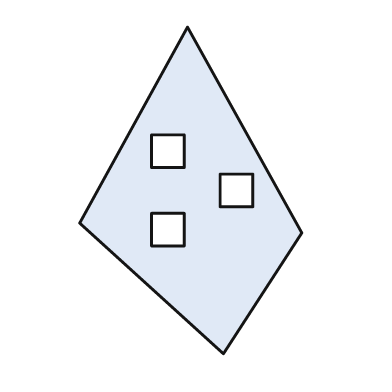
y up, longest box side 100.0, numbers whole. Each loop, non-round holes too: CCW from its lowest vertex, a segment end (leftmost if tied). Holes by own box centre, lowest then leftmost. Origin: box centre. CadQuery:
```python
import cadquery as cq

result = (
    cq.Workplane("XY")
    .moveTo(10.0, -50.0)
    .lineTo(34.0, -13.0)
    .lineTo(-1.0, 50.0)
    .lineTo(-34.0, -10.0)
    .close()
    .moveTo(-12.0, -17.0)
    .lineTo(-2.0, -17.0)
    .lineTo(-2.0, -7.0)
    .lineTo(-12.0, -7.0)
    .close()
    .moveTo(9.0, -5.0)
    .lineTo(19.0, -5.0)
    .lineTo(19.0, 5.0)
    .lineTo(9.0, 5.0)
    .close()
    .moveTo(-12.0, 7.0)
    .lineTo(-2.0, 7.0)
    .lineTo(-2.0, 17.0)
    .lineTo(-12.0, 17.0)
    .close()
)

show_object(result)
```